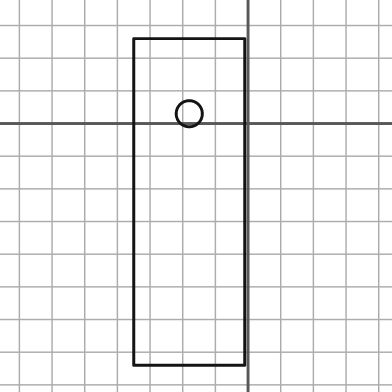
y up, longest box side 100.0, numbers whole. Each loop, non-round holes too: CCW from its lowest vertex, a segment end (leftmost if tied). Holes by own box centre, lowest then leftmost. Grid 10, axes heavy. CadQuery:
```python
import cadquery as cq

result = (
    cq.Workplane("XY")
    .moveTo(-35.0, -74.0)
    .lineTo(-1.0, -74.0)
    .lineTo(-1.0, 26.0)
    .lineTo(-35.0, 26.0)
    .close()
    .moveTo(-18.0, 3.0)
    .circle(4.0)
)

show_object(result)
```